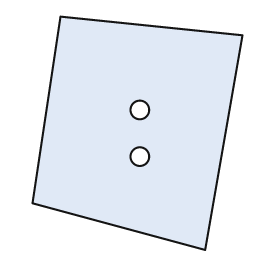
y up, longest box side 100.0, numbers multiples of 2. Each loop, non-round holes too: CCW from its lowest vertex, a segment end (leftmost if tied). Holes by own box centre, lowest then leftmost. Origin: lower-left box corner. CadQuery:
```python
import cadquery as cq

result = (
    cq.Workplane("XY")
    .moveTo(74.0, 0.0)
    .lineTo(90.0, 92.0)
    .lineTo(12.0, 100.0)
    .lineTo(0.0, 20.0)
    .close()
    .moveTo(46.0, 40.0)
    .circle(4.0)
    .moveTo(46.0, 60.0)
    .circle(4.0)
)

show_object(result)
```